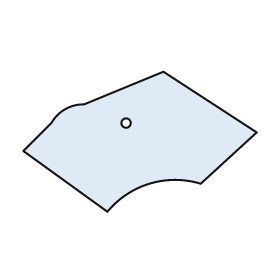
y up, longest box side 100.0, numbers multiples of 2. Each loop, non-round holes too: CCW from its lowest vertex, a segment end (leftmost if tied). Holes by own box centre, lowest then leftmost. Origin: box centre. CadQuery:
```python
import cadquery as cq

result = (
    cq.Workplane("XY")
    .moveTo(-14.0, -30.0)
    .threePointArc((4.0, -18.0), (26.0, -18.0))
    .lineTo(50.0, 4.0)
    .lineTo(10.0, 30.0)
    .lineTo(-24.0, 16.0)
    .threePointArc((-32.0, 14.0), (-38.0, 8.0))
    .lineTo(-50.0, -4.0)
    .close()
    .moveTo(-6.0, 8.0)
    .circle(2.0)
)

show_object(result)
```